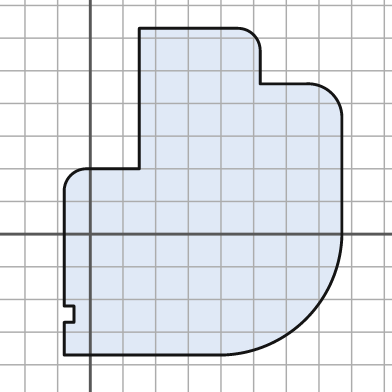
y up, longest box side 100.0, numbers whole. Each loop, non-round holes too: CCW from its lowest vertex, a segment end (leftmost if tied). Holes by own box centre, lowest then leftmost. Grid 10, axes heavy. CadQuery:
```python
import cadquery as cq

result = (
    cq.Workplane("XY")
    .moveTo(-8.0, -37.0)
    .lineTo(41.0, -37.0)
    .threePointArc((66.0, -26.0), (77.0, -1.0))
    .lineTo(77.0, 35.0)
    .threePointArc((74.0, 43.0), (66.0, 46.0))
    .lineTo(52.0, 46.0)
    .lineTo(52.0, 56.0)
    .threePointArc((50.0, 61.0), (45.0, 63.0))
    .lineTo(15.0, 63.0)
    .lineTo(15.0, 20.0)
    .lineTo(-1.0, 20.0)
    .threePointArc((-6.0, 18.0), (-8.0, 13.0))
    .lineTo(-8.0, -22.0)
    .lineTo(-5.0, -22.0)
    .lineTo(-5.0, -27.0)
    .lineTo(-8.0, -27.0)
    .close()
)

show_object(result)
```